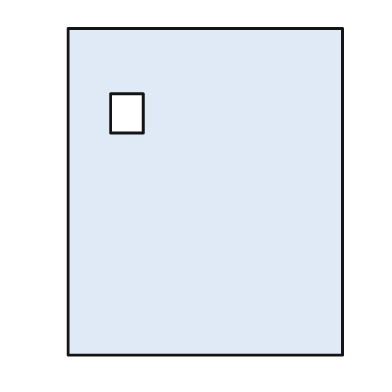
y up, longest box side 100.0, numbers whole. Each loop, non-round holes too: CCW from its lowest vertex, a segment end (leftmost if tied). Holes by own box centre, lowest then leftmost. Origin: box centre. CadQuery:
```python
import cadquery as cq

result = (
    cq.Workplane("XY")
    .moveTo(-42.0, -50.0)
    .lineTo(42.0, -50.0)
    .lineTo(42.0, 50.0)
    .lineTo(-42.0, 50.0)
    .close()
    .moveTo(-29.0, 18.0)
    .lineTo(-19.0, 18.0)
    .lineTo(-19.0, 30.0)
    .lineTo(-29.0, 30.0)
    .close()
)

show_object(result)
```